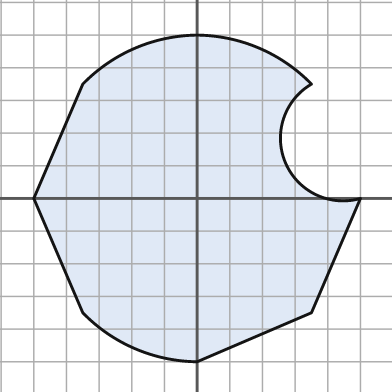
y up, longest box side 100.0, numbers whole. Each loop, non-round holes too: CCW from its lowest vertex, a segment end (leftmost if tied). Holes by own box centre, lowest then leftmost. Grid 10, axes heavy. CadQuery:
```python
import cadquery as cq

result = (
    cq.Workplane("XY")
    .moveTo(0.0, -50.0)
    .lineTo(35.0, -35.0)
    .lineTo(50.0, 0.0)
    .threePointArc((27.0, 11.0), (35.0, 35.0))
    .threePointArc((19.0, 46.0), (0.0, 50.0))
    .threePointArc((-19.0, 46.0), (-35.0, 35.0))
    .lineTo(-50.0, 0.0)
    .lineTo(-35.0, -35.0)
    .threePointArc((-19.0, -46.0), (0.0, -50.0))
    .close()
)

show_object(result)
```